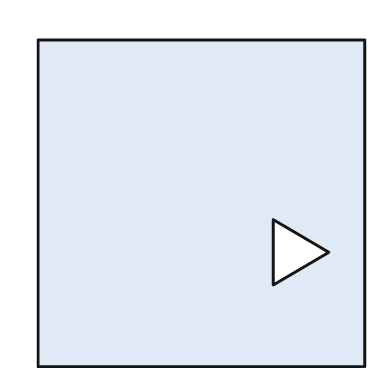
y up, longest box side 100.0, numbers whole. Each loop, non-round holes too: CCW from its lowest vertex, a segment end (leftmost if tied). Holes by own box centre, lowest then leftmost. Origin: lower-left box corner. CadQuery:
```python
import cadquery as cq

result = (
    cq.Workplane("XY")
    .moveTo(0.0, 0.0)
    .lineTo(100.0, 0.0)
    .lineTo(100.0, 100.0)
    .lineTo(0.0, 100.0)
    .close()
    .moveTo(72.0, 25.0)
    .lineTo(89.0, 35.0)
    .lineTo(72.0, 45.0)
    .close()
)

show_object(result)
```